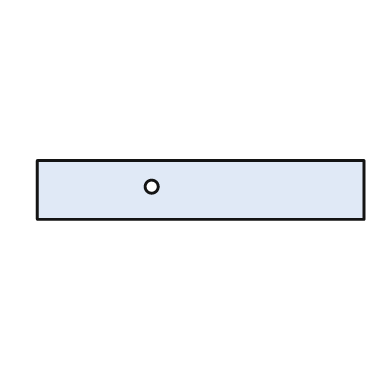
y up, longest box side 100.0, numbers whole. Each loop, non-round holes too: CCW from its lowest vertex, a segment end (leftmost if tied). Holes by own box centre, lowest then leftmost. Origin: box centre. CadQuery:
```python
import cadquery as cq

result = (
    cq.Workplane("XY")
    .moveTo(-50.0, -9.0)
    .lineTo(50.0, -9.0)
    .lineTo(50.0, 9.0)
    .lineTo(-50.0, 9.0)
    .close()
    .moveTo(-15.0, 1.0)
    .circle(2.0)
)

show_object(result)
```